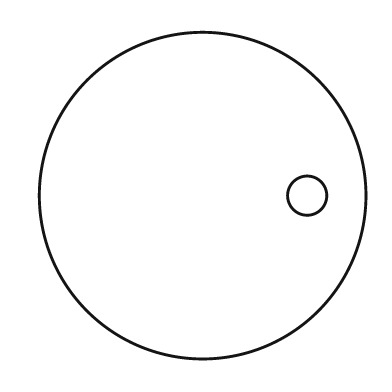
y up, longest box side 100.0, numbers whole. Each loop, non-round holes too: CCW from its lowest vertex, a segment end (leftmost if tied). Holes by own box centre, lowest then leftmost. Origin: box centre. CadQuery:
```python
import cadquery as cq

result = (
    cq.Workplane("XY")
    .moveTo(0.0, 0.0)
    .circle(50.0)
    .moveTo(32.0, 0.0)
    .circle(6.0)
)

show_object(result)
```